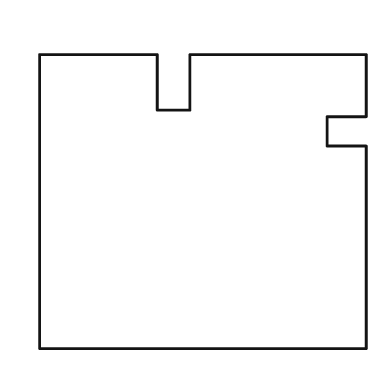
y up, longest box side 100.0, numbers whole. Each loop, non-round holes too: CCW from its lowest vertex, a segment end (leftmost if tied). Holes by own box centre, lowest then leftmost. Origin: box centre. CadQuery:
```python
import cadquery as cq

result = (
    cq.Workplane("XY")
    .moveTo(-50.0, -45.0)
    .lineTo(50.0, -45.0)
    .lineTo(50.0, 17.0)
    .lineTo(38.0, 17.0)
    .lineTo(38.0, 26.0)
    .lineTo(50.0, 26.0)
    .lineTo(50.0, 45.0)
    .lineTo(-4.0, 45.0)
    .lineTo(-4.0, 28.0)
    .lineTo(-14.0, 28.0)
    .lineTo(-14.0, 45.0)
    .lineTo(-50.0, 45.0)
    .close()
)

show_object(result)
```